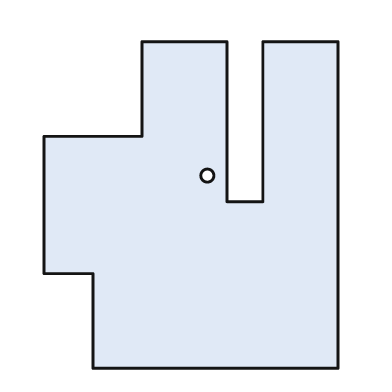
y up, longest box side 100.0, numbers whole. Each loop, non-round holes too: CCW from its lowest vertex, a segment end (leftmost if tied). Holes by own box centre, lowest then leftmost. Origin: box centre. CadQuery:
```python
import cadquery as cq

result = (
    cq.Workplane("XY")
    .moveTo(-30.0, -50.0)
    .lineTo(45.0, -50.0)
    .lineTo(45.0, 50.0)
    .lineTo(22.0, 50.0)
    .lineTo(22.0, 1.0)
    .lineTo(11.0, 1.0)
    .lineTo(11.0, 50.0)
    .lineTo(-15.0, 50.0)
    .lineTo(-15.0, 21.0)
    .lineTo(-45.0, 21.0)
    .lineTo(-45.0, -21.0)
    .lineTo(-30.0, -21.0)
    .close()
    .moveTo(5.0, 9.0)
    .circle(2.0)
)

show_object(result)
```